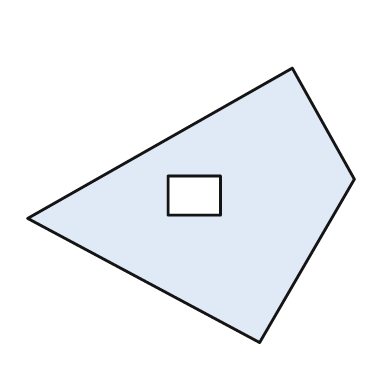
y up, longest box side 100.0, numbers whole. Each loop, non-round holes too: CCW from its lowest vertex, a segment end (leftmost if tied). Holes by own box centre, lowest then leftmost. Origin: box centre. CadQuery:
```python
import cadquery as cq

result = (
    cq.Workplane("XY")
    .moveTo(21.0, -42.0)
    .lineTo(50.0, 8.0)
    .lineTo(31.0, 42.0)
    .lineTo(-50.0, -4.0)
    .close()
    .moveTo(-7.0, -3.0)
    .lineTo(9.0, -3.0)
    .lineTo(9.0, 9.0)
    .lineTo(-7.0, 9.0)
    .close()
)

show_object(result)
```